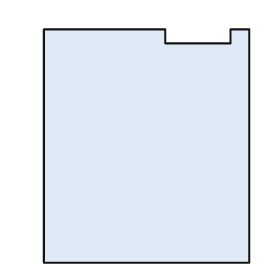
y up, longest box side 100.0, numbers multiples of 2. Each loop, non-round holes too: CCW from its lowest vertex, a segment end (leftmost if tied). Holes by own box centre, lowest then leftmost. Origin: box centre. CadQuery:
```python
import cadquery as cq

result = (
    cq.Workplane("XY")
    .moveTo(-44.0, -50.0)
    .lineTo(44.0, -50.0)
    .lineTo(44.0, 50.0)
    .lineTo(36.0, 50.0)
    .lineTo(36.0, 44.0)
    .lineTo(8.0, 44.0)
    .lineTo(8.0, 50.0)
    .lineTo(-44.0, 50.0)
    .close()
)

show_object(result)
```